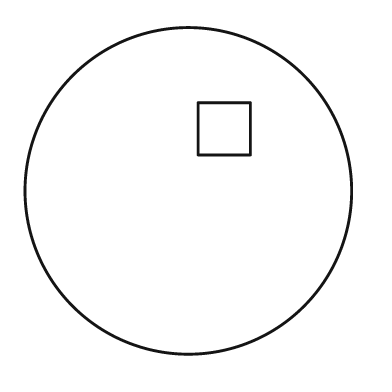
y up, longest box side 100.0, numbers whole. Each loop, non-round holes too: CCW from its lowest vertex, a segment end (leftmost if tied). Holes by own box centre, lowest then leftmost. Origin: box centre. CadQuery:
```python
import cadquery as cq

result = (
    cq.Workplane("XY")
    .moveTo(0.0, 0.0)
    .circle(50.0)
    .moveTo(3.0, 11.0)
    .lineTo(19.0, 11.0)
    .lineTo(19.0, 27.0)
    .lineTo(3.0, 27.0)
    .close()
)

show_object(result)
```